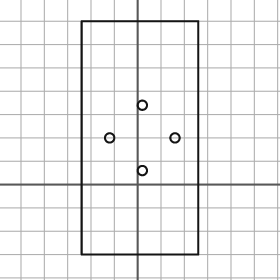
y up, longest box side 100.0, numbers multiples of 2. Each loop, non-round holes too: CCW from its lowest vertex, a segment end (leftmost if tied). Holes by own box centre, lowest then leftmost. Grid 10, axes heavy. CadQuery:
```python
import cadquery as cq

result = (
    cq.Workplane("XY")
    .moveTo(-24.0, -30.0)
    .lineTo(26.0, -30.0)
    .lineTo(26.0, 70.0)
    .lineTo(-24.0, 70.0)
    .close()
    .moveTo(2.0, 6.0)
    .circle(2.0)
    .moveTo(-12.0, 20.0)
    .circle(2.0)
    .moveTo(16.0, 20.0)
    .circle(2.0)
    .moveTo(2.0, 34.0)
    .circle(2.0)
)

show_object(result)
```